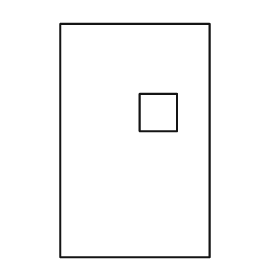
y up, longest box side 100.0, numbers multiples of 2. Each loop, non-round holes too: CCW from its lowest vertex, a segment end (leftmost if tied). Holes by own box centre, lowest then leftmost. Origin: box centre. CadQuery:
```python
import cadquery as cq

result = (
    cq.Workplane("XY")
    .moveTo(-32.0, -50.0)
    .lineTo(32.0, -50.0)
    .lineTo(32.0, 50.0)
    .lineTo(-32.0, 50.0)
    .close()
    .moveTo(2.0, 4.0)
    .lineTo(18.0, 4.0)
    .lineTo(18.0, 20.0)
    .lineTo(2.0, 20.0)
    .close()
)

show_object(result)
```